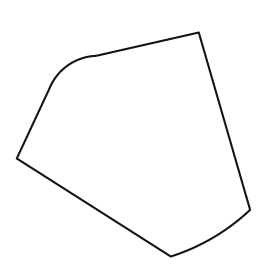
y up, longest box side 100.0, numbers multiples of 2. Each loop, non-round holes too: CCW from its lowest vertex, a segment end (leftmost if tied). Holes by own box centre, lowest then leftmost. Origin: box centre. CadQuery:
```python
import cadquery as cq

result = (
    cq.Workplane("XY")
    .moveTo(16.0, -48.0)
    .threePointArc((34.0, -40.0), (50.0, -28.0))
    .lineTo(28.0, 48.0)
    .lineTo(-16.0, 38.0)
    .threePointArc((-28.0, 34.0), (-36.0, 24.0))
    .lineTo(-50.0, -6.0)
    .close()
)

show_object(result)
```